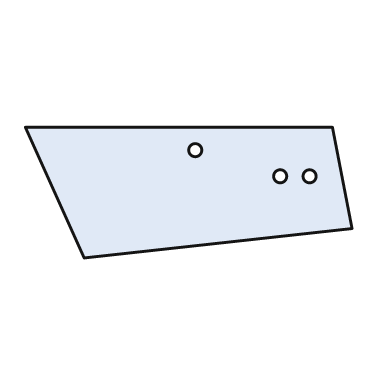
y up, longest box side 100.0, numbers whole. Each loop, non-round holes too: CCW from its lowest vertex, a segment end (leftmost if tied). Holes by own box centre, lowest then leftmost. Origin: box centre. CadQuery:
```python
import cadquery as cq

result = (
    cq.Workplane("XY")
    .moveTo(-32.0, -20.0)
    .lineTo(50.0, -11.0)
    .lineTo(44.0, 20.0)
    .lineTo(-50.0, 20.0)
    .close()
    .moveTo(28.0, 5.0)
    .circle(2.0)
    .moveTo(37.0, 5.0)
    .circle(2.0)
    .moveTo(2.0, 13.0)
    .circle(2.0)
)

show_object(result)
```